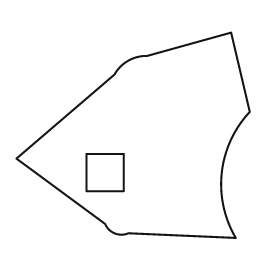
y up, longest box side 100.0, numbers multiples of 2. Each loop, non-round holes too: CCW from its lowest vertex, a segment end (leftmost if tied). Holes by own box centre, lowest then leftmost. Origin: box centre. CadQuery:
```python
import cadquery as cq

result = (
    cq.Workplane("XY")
    .moveTo(44.0, -44.0)
    .threePointArc((38.0, -16.0), (50.0, 10.0))
    .lineTo(42.0, 44.0)
    .lineTo(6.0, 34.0)
    .threePointArc((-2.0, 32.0), (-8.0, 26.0))
    .lineTo(-50.0, -10.0)
    .lineTo(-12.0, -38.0)
    .threePointArc((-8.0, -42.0), (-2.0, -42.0))
    .close()
    .moveTo(-20.0, -24.0)
    .lineTo(-4.0, -24.0)
    .lineTo(-4.0, -8.0)
    .lineTo(-20.0, -8.0)
    .close()
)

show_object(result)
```